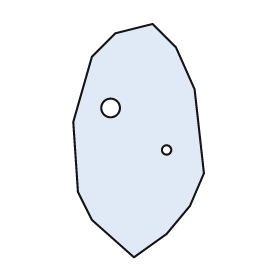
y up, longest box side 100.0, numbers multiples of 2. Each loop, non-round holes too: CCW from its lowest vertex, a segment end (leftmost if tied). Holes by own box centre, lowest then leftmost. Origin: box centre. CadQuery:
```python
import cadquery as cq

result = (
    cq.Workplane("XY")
    .moveTo(-2.0, -50.0)
    .lineTo(12.0, -40.0)
    .lineTo(22.0, -28.0)
    .lineTo(28.0, -14.0)
    .lineTo(24.0, 22.0)
    .lineTo(16.0, 40.0)
    .lineTo(6.0, 50.0)
    .lineTo(-10.0, 46.0)
    .lineTo(-20.0, 36.0)
    .lineTo(-28.0, 8.0)
    .lineTo(-26.0, -22.0)
    .lineTo(-20.0, -34.0)
    .close()
    .moveTo(12.0, -4.0)
    .circle(2.0)
    .moveTo(-12.0, 14.0)
    .circle(4.0)
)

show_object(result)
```